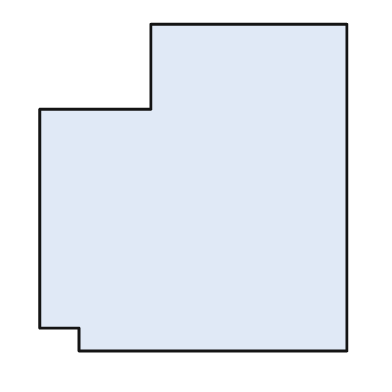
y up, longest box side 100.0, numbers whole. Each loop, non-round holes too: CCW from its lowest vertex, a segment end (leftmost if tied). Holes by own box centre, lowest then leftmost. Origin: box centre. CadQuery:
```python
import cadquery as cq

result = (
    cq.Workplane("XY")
    .moveTo(-35.0, -50.0)
    .lineTo(47.0, -50.0)
    .lineTo(47.0, 50.0)
    .lineTo(-13.0, 50.0)
    .lineTo(-13.0, 24.0)
    .lineTo(-47.0, 24.0)
    .lineTo(-47.0, -43.0)
    .lineTo(-35.0, -43.0)
    .close()
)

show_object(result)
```